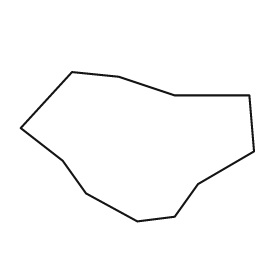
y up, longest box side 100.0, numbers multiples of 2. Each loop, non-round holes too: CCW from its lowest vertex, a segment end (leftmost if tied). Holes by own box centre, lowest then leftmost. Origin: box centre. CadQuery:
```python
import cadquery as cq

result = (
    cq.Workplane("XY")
    .moveTo(0.0, -32.0)
    .lineTo(16.0, -30.0)
    .lineTo(26.0, -16.0)
    .lineTo(50.0, -2.0)
    .lineTo(48.0, 22.0)
    .lineTo(16.0, 22.0)
    .lineTo(-8.0, 30.0)
    .lineTo(-28.0, 32.0)
    .lineTo(-50.0, 8.0)
    .lineTo(-32.0, -6.0)
    .lineTo(-22.0, -20.0)
    .close()
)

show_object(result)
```